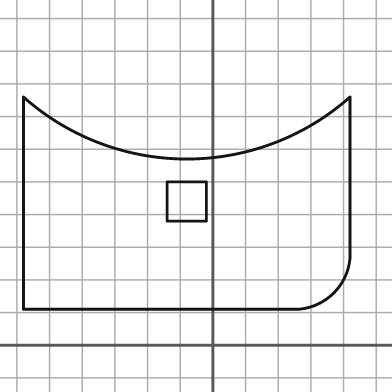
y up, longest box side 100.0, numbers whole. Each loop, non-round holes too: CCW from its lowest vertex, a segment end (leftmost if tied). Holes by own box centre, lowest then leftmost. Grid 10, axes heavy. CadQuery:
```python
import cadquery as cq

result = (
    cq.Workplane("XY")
    .moveTo(-58.0, 11.0)
    .lineTo(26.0, 11.0)
    .threePointArc((37.0, 16.0), (42.0, 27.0))
    .lineTo(42.0, 76.0)
    .threePointArc((-8.0, 57.0), (-58.0, 76.0))
    .close()
    .moveTo(-14.0, 38.0)
    .lineTo(-2.0, 38.0)
    .lineTo(-2.0, 50.0)
    .lineTo(-14.0, 50.0)
    .close()
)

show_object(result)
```